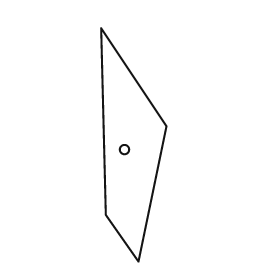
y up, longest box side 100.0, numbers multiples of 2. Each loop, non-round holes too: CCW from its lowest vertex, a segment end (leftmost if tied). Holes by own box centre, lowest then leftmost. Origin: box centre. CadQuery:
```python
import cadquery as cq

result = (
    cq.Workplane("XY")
    .moveTo(2.0, -50.0)
    .lineTo(14.0, 8.0)
    .lineTo(-14.0, 50.0)
    .lineTo(-12.0, -30.0)
    .close()
    .moveTo(-4.0, -2.0)
    .circle(2.0)
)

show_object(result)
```